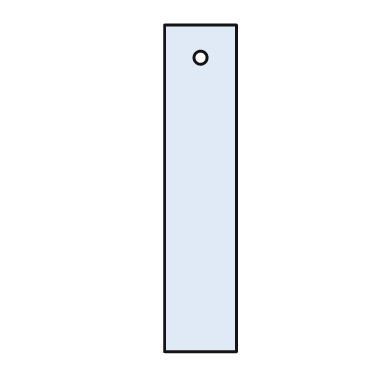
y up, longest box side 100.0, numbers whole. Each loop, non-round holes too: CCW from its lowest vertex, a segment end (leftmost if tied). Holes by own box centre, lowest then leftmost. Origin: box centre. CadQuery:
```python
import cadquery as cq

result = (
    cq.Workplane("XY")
    .moveTo(-11.0, -50.0)
    .lineTo(11.0, -50.0)
    .lineTo(11.0, 50.0)
    .lineTo(-11.0, 50.0)
    .close()
    .moveTo(0.0, 40.0)
    .circle(2.0)
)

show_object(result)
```